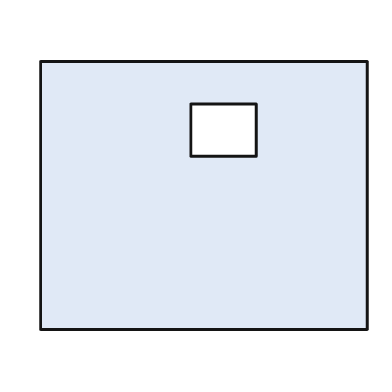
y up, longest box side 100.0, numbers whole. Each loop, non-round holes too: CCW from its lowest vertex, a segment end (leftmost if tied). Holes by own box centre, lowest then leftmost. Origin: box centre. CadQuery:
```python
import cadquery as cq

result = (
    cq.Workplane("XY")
    .moveTo(-50.0, -41.0)
    .lineTo(50.0, -41.0)
    .lineTo(50.0, 41.0)
    .lineTo(-50.0, 41.0)
    .close()
    .moveTo(-4.0, 12.0)
    .lineTo(16.0, 12.0)
    .lineTo(16.0, 28.0)
    .lineTo(-4.0, 28.0)
    .close()
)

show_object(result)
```